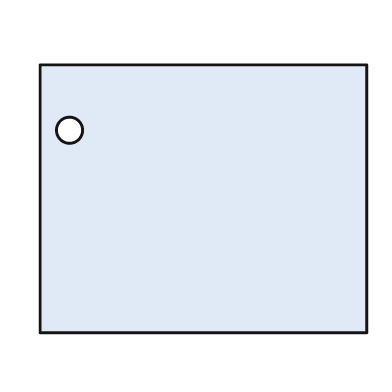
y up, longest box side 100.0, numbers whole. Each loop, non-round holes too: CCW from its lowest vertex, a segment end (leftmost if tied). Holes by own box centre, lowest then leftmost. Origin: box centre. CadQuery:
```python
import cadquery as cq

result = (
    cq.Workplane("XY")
    .moveTo(-50.0, -41.0)
    .lineTo(50.0, -41.0)
    .lineTo(50.0, 41.0)
    .lineTo(-50.0, 41.0)
    .close()
    .moveTo(-41.0, 21.0)
    .circle(4.0)
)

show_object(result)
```